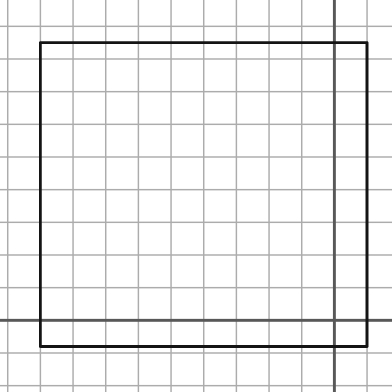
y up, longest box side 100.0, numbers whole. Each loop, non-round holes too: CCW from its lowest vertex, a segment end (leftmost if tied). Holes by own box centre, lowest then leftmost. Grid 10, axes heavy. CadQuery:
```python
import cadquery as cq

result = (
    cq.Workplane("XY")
    .moveTo(-90.0, -8.0)
    .lineTo(10.0, -8.0)
    .lineTo(10.0, 85.0)
    .lineTo(-90.0, 85.0)
    .close()
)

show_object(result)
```